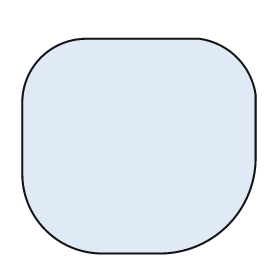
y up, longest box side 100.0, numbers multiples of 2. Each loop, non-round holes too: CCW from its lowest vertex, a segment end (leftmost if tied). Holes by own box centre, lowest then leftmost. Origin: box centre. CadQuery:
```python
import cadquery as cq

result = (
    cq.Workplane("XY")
    .moveTo(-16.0, -46.0)
    .lineTo(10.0, -46.0)
    .threePointArc((38.0, -34.0), (50.0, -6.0))
    .lineTo(50.0, 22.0)
    .threePointArc((42.0, 38.0), (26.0, 46.0))
    .lineTo(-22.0, 46.0)
    .threePointArc((-42.0, 38.0), (-50.0, 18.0))
    .lineTo(-50.0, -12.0)
    .threePointArc((-40.0, -36.0), (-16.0, -46.0))
    .close()
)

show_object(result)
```